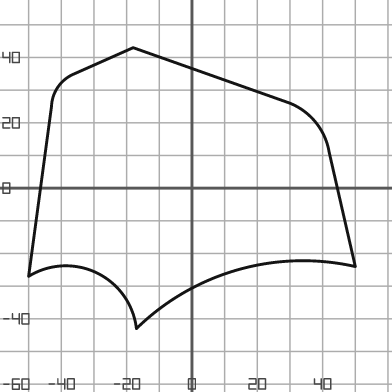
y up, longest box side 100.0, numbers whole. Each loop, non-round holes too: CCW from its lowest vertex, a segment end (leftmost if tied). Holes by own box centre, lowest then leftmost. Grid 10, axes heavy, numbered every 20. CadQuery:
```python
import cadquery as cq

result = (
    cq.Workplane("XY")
    .moveTo(-17.0, -43.0)
    .threePointArc((14.0, -25.0), (50.0, -24.0))
    .lineTo(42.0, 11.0)
    .threePointArc((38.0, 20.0), (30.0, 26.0))
    .lineTo(-18.0, 43.0)
    .lineTo(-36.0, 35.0)
    .threePointArc((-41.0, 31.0), (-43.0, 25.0))
    .lineTo(-50.0, -27.0)
    .threePointArc((-29.0, -26.0), (-17.0, -43.0))
    .close()
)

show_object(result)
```